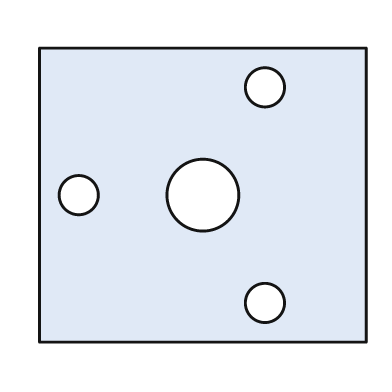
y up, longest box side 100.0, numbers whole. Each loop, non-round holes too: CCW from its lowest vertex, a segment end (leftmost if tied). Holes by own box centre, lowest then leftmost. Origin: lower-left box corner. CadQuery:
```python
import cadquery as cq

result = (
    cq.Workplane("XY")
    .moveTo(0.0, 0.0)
    .lineTo(100.0, 0.0)
    .lineTo(100.0, 90.0)
    .lineTo(0.0, 90.0)
    .close()
    .moveTo(69.0, 12.0)
    .circle(6.0)
    .moveTo(12.0, 45.0)
    .circle(6.0)
    .moveTo(50.0, 45.0)
    .circle(11.0)
    .moveTo(69.0, 78.0)
    .circle(6.0)
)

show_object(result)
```